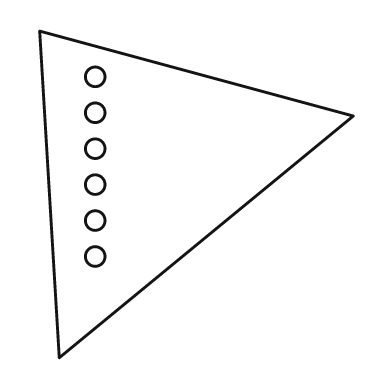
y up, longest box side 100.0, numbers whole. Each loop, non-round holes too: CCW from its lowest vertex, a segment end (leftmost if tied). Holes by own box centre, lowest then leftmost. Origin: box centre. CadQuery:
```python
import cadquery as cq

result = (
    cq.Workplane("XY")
    .moveTo(-42.0, -50.0)
    .lineTo(48.0, 24.0)
    .lineTo(-48.0, 50.0)
    .close()
    .moveTo(-31.0, -19.0)
    .circle(3.0)
    .moveTo(-31.0, -8.0)
    .circle(3.0)
    .moveTo(-31.0, 3.0)
    .circle(3.0)
    .moveTo(-31.0, 14.0)
    .circle(3.0)
    .moveTo(-31.0, 25.0)
    .circle(3.0)
    .moveTo(-31.0, 36.0)
    .circle(3.0)
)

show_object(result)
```